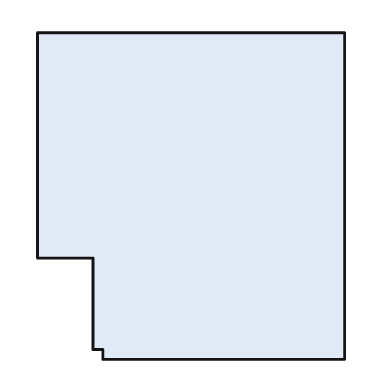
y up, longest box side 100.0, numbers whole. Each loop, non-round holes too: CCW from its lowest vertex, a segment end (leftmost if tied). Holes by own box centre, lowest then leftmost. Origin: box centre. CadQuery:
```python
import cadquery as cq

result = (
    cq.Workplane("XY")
    .moveTo(-27.0, -50.0)
    .lineTo(47.0, -50.0)
    .lineTo(47.0, 50.0)
    .lineTo(-47.0, 50.0)
    .lineTo(-47.0, -19.0)
    .lineTo(-30.0, -19.0)
    .lineTo(-30.0, -47.0)
    .lineTo(-27.0, -47.0)
    .close()
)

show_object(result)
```